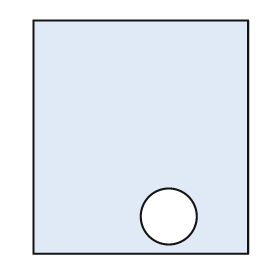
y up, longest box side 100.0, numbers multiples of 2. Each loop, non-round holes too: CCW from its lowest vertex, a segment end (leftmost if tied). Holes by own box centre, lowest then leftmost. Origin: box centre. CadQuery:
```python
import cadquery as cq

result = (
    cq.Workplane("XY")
    .moveTo(-46.0, -50.0)
    .lineTo(46.0, -50.0)
    .lineTo(46.0, 50.0)
    .lineTo(-46.0, 50.0)
    .close()
    .moveTo(12.0, -34.0)
    .circle(12.0)
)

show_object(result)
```